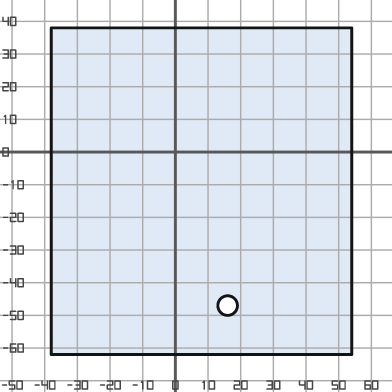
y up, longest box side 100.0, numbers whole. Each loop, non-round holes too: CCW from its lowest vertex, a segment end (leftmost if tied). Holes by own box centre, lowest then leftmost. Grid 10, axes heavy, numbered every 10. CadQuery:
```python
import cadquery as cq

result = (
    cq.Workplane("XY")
    .moveTo(-38.0, -62.0)
    .lineTo(54.0, -62.0)
    .lineTo(54.0, 38.0)
    .lineTo(-38.0, 38.0)
    .close()
    .moveTo(16.0, -47.0)
    .circle(3.0)
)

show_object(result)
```